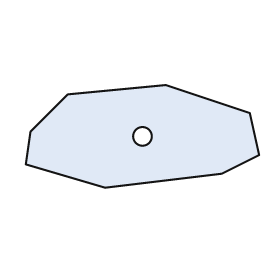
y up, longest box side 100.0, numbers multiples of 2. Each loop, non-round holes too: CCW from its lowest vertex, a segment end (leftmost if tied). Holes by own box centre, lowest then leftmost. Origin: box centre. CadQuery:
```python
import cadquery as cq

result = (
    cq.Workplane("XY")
    .moveTo(-16.0, -22.0)
    .lineTo(34.0, -16.0)
    .lineTo(50.0, -8.0)
    .lineTo(46.0, 10.0)
    .lineTo(10.0, 22.0)
    .lineTo(-32.0, 18.0)
    .lineTo(-48.0, 2.0)
    .lineTo(-50.0, -12.0)
    .close()
    .moveTo(0.0, 0.0)
    .circle(4.0)
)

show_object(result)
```